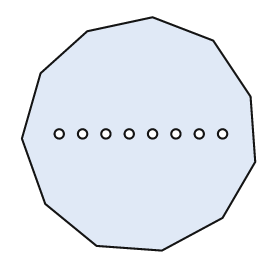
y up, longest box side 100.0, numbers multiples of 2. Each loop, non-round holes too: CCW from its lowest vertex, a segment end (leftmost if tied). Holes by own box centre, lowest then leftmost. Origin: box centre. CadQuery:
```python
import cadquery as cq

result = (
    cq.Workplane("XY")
    .moveTo(10.0, -50.0)
    .lineTo(36.0, -36.0)
    .lineTo(50.0, -12.0)
    .lineTo(48.0, 16.0)
    .lineTo(32.0, 40.0)
    .lineTo(6.0, 50.0)
    .lineTo(-22.0, 44.0)
    .lineTo(-42.0, 26.0)
    .lineTo(-50.0, -2.0)
    .lineTo(-40.0, -30.0)
    .lineTo(-18.0, -48.0)
    .close()
    .moveTo(-34.0, 0.0)
    .circle(2.0)
    .moveTo(-24.0, 0.0)
    .circle(2.0)
    .moveTo(-14.0, 0.0)
    .circle(2.0)
    .moveTo(-4.0, 0.0)
    .circle(2.0)
    .moveTo(6.0, 0.0)
    .circle(2.0)
    .moveTo(16.0, 0.0)
    .circle(2.0)
    .moveTo(26.0, 0.0)
    .circle(2.0)
    .moveTo(36.0, 0.0)
    .circle(2.0)
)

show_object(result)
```